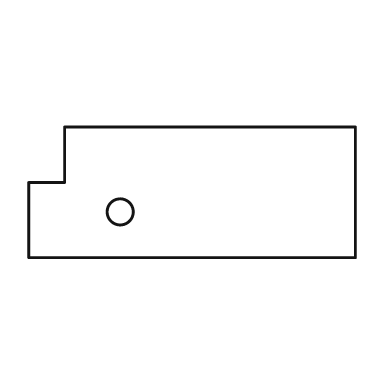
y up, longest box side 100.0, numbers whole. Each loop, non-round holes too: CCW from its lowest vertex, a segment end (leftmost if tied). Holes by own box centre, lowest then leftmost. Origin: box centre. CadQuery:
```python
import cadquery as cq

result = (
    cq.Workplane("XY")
    .moveTo(-50.0, -20.0)
    .lineTo(50.0, -20.0)
    .lineTo(50.0, 20.0)
    .lineTo(-39.0, 20.0)
    .lineTo(-39.0, 3.0)
    .lineTo(-50.0, 3.0)
    .close()
    .moveTo(-22.0, -6.0)
    .circle(4.0)
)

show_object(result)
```